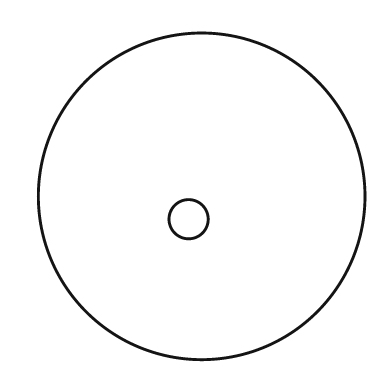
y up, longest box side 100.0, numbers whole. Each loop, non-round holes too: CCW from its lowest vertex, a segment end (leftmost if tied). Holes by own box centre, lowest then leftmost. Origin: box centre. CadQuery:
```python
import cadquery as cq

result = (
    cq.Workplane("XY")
    .moveTo(0.0, 0.0)
    .circle(50.0)
    .moveTo(-4.0, -7.0)
    .circle(6.0)
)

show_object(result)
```